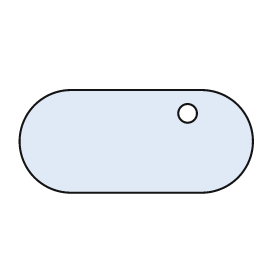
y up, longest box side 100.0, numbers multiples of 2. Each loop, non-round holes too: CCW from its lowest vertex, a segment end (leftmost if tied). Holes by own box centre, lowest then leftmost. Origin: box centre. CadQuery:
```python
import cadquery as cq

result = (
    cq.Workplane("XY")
    .moveTo(-28.0, -22.0)
    .lineTo(28.0, -22.0)
    .threePointArc((50.0, 0.0), (28.0, 22.0))
    .lineTo(-28.0, 22.0)
    .threePointArc((-50.0, 0.0), (-28.0, -22.0))
    .close()
    .moveTo(22.0, 12.0)
    .circle(4.0)
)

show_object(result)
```